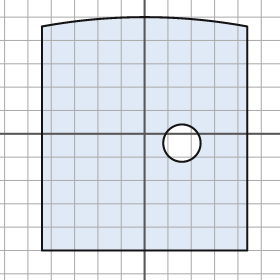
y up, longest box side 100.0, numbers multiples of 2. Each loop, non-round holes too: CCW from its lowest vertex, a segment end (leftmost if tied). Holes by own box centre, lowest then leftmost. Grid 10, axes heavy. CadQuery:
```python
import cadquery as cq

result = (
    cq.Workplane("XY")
    .moveTo(-44.0, -50.0)
    .lineTo(44.0, -50.0)
    .lineTo(44.0, 46.0)
    .threePointArc((0.0, 50.0), (-44.0, 46.0))
    .close()
    .moveTo(16.0, -4.0)
    .circle(8.0)
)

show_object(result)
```